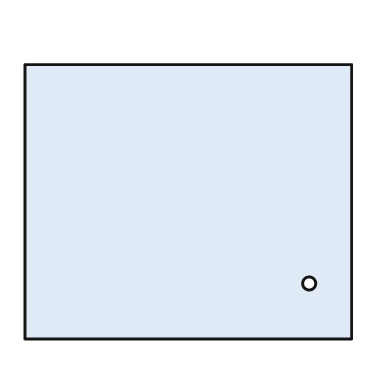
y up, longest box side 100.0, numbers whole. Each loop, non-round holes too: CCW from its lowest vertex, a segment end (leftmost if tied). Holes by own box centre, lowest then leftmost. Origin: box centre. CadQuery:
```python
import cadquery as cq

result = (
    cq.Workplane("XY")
    .moveTo(-50.0, -42.0)
    .lineTo(50.0, -42.0)
    .lineTo(50.0, 42.0)
    .lineTo(-50.0, 42.0)
    .close()
    .moveTo(37.0, -25.0)
    .circle(2.0)
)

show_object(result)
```